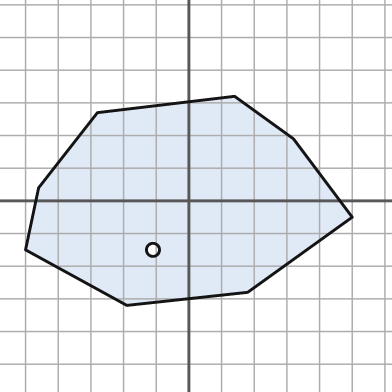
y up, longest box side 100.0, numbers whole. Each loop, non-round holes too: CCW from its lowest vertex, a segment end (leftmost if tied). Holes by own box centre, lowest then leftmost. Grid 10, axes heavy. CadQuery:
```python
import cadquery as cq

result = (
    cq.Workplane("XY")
    .moveTo(-19.0, -32.0)
    .lineTo(18.0, -28.0)
    .lineTo(50.0, -5.0)
    .lineTo(32.0, 19.0)
    .lineTo(14.0, 32.0)
    .lineTo(-28.0, 27.0)
    .lineTo(-46.0, 4.0)
    .lineTo(-50.0, -15.0)
    .close()
    .moveTo(-11.0, -15.0)
    .circle(2.0)
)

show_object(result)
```